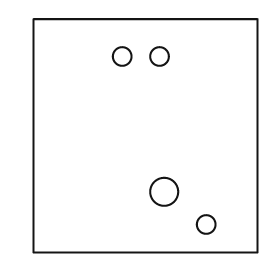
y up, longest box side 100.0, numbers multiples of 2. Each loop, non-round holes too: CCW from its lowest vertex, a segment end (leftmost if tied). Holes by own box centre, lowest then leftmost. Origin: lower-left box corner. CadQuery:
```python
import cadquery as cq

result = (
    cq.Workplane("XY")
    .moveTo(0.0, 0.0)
    .lineTo(96.0, 0.0)
    .lineTo(96.0, 100.0)
    .lineTo(0.0, 100.0)
    .close()
    .moveTo(74.0, 12.0)
    .circle(4.0)
    .moveTo(56.0, 26.0)
    .circle(6.0)
    .moveTo(38.0, 84.0)
    .circle(4.0)
    .moveTo(54.0, 84.0)
    .circle(4.0)
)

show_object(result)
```